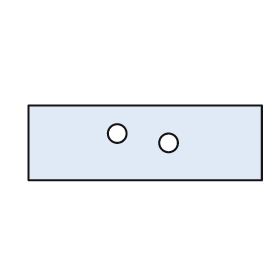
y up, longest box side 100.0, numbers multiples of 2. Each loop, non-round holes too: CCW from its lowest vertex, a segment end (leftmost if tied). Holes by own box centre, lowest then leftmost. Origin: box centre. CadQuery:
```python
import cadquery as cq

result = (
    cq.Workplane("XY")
    .moveTo(-50.0, -16.0)
    .lineTo(50.0, -16.0)
    .lineTo(50.0, 16.0)
    .lineTo(-50.0, 16.0)
    .close()
    .moveTo(10.0, 0.0)
    .circle(4.0)
    .moveTo(-12.0, 4.0)
    .circle(4.0)
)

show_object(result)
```